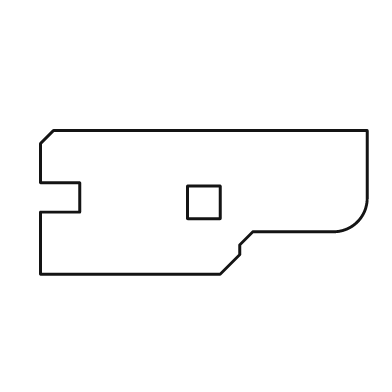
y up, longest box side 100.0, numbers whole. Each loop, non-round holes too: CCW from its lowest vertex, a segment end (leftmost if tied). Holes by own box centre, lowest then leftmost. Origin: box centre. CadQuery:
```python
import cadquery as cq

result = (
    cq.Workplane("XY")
    .moveTo(-50.0, -22.0)
    .lineTo(5.0, -22.0)
    .lineTo(11.0, -16.0)
    .lineTo(11.0, -13.0)
    .lineTo(15.0, -9.0)
    .lineTo(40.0, -9.0)
    .threePointArc((47.0, -6.0), (50.0, 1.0))
    .lineTo(50.0, 22.0)
    .lineTo(-46.0, 22.0)
    .lineTo(-50.0, 18.0)
    .lineTo(-50.0, 6.0)
    .lineTo(-38.0, 6.0)
    .lineTo(-38.0, -3.0)
    .lineTo(-50.0, -3.0)
    .close()
    .moveTo(-5.0, -5.0)
    .lineTo(5.0, -5.0)
    .lineTo(5.0, 5.0)
    .lineTo(-5.0, 5.0)
    .close()
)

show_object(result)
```